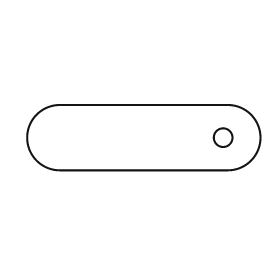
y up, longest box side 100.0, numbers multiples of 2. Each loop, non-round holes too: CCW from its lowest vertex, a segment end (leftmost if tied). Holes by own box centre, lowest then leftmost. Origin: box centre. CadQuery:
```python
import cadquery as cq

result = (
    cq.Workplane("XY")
    .moveTo(-36.0, -14.0)
    .lineTo(36.0, -14.0)
    .threePointArc((50.0, 0.0), (36.0, 14.0))
    .lineTo(-36.0, 14.0)
    .threePointArc((-50.0, 0.0), (-36.0, -14.0))
    .close()
    .moveTo(34.0, 0.0)
    .circle(4.0)
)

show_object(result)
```